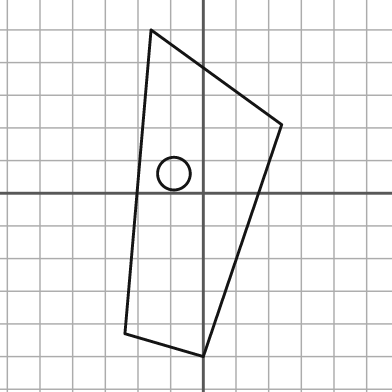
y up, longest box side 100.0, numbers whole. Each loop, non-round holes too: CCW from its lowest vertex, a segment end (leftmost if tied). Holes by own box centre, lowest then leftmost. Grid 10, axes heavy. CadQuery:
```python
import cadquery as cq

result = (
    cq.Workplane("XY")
    .moveTo(0.0, -50.0)
    .lineTo(24.0, 21.0)
    .lineTo(-16.0, 50.0)
    .lineTo(-24.0, -43.0)
    .close()
    .moveTo(-9.0, 6.0)
    .circle(5.0)
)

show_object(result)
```